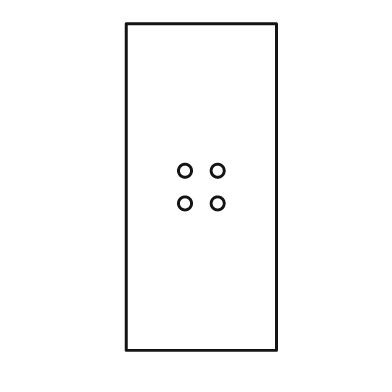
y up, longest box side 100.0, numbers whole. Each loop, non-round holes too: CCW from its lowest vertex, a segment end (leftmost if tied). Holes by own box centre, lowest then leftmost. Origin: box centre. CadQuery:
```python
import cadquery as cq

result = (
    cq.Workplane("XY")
    .moveTo(-23.0, -50.0)
    .lineTo(23.0, -50.0)
    .lineTo(23.0, 50.0)
    .lineTo(-23.0, 50.0)
    .close()
    .moveTo(-5.0, -5.0)
    .circle(2.0)
    .moveTo(5.0, -5.0)
    .circle(2.0)
    .moveTo(-5.0, 5.0)
    .circle(2.0)
    .moveTo(5.0, 5.0)
    .circle(2.0)
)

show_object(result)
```